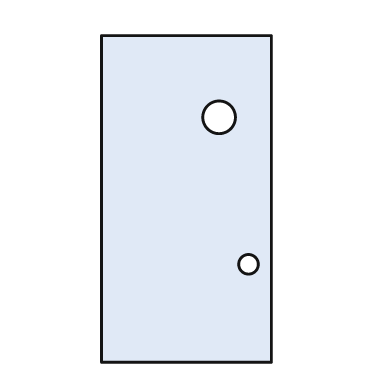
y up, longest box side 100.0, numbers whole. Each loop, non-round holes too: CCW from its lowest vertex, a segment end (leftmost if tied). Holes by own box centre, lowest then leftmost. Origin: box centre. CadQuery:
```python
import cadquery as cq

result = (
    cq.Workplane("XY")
    .moveTo(-26.0, -50.0)
    .lineTo(26.0, -50.0)
    .lineTo(26.0, 50.0)
    .lineTo(-26.0, 50.0)
    .close()
    .moveTo(19.0, -20.0)
    .circle(3.0)
    .moveTo(10.0, 25.0)
    .circle(5.0)
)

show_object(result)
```